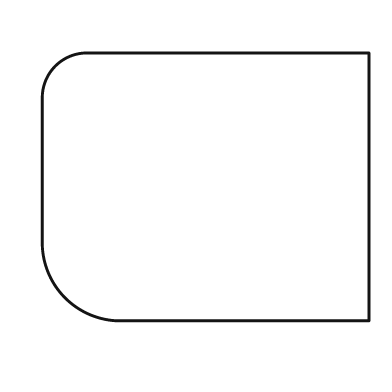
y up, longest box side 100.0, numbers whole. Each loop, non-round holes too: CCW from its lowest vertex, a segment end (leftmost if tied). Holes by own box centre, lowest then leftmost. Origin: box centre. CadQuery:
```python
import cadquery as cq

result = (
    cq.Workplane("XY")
    .moveTo(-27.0, -41.0)
    .lineTo(50.0, -41.0)
    .lineTo(50.0, 41.0)
    .lineTo(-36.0, 41.0)
    .threePointArc((-46.0, 37.0), (-50.0, 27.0))
    .lineTo(-50.0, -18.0)
    .threePointArc((-43.0, -34.0), (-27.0, -41.0))
    .close()
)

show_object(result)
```